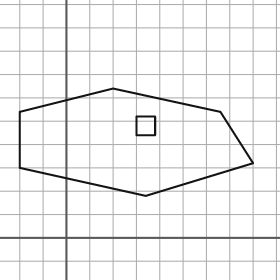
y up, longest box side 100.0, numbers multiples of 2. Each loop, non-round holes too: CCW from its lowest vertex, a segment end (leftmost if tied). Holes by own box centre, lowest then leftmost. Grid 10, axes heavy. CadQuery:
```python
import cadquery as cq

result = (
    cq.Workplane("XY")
    .moveTo(34.0, 18.0)
    .lineTo(80.0, 32.0)
    .lineTo(66.0, 54.0)
    .lineTo(20.0, 64.0)
    .lineTo(-20.0, 54.0)
    .lineTo(-20.0, 30.0)
    .close()
    .moveTo(30.0, 44.0)
    .lineTo(38.0, 44.0)
    .lineTo(38.0, 52.0)
    .lineTo(30.0, 52.0)
    .close()
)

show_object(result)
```